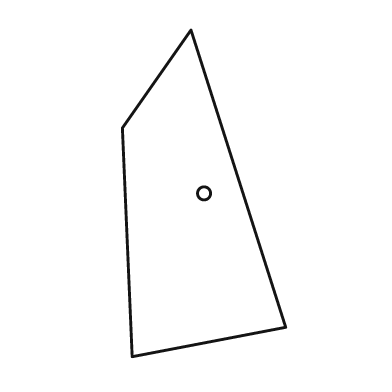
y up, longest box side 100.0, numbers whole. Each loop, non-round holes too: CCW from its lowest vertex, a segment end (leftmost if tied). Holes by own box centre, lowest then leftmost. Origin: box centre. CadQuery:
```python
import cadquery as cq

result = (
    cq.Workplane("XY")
    .moveTo(-22.0, -50.0)
    .lineTo(25.0, -41.0)
    .lineTo(-4.0, 50.0)
    .lineTo(-25.0, 20.0)
    .close()
    .moveTo(0.0, 0.0)
    .circle(2.0)
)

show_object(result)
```